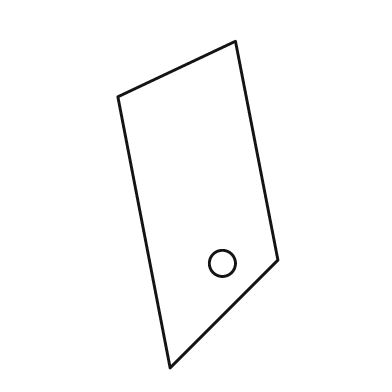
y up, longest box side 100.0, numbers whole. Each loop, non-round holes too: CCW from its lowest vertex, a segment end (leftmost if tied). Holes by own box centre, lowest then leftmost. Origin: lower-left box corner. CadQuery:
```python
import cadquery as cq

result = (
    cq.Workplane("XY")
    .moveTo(16.0, 0.0)
    .lineTo(49.0, 33.0)
    .lineTo(36.0, 100.0)
    .lineTo(0.0, 83.0)
    .close()
    .moveTo(32.0, 32.0)
    .circle(4.0)
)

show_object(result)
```